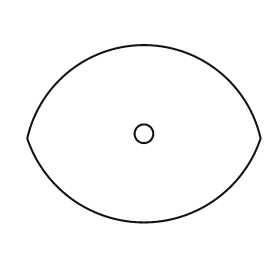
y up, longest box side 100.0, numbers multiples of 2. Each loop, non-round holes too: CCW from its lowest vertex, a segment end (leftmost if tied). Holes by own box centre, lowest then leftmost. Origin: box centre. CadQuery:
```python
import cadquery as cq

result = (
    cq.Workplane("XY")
    .moveTo(-50.0, -2.0)
    .threePointArc((0.0, -38.0), (50.0, -2.0))
    .threePointArc((0.0, 38.0), (-50.0, -2.0))
    .close()
    .moveTo(0.0, 0.0)
    .circle(4.0)
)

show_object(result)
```